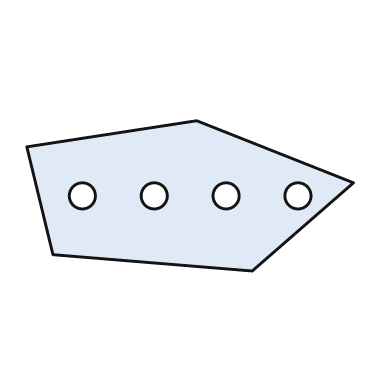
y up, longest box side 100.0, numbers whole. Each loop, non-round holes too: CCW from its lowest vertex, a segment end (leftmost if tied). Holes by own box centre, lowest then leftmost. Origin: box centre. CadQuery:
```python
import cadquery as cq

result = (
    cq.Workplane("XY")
    .moveTo(19.0, -23.0)
    .lineTo(50.0, 4.0)
    .lineTo(2.0, 23.0)
    .lineTo(-50.0, 15.0)
    .lineTo(-42.0, -18.0)
    .close()
    .moveTo(-33.0, 0.0)
    .circle(4.0)
    .moveTo(-11.0, 0.0)
    .circle(4.0)
    .moveTo(11.0, 0.0)
    .circle(4.0)
    .moveTo(33.0, 0.0)
    .circle(4.0)
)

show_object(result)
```